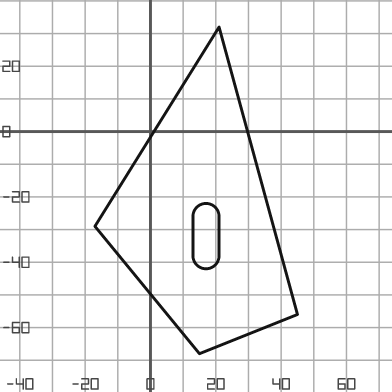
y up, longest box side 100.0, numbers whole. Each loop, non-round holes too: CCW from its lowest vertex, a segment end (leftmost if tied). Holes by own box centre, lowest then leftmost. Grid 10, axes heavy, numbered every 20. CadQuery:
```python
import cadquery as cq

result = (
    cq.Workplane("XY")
    .moveTo(15.0, -68.0)
    .lineTo(45.0, -56.0)
    .lineTo(21.0, 32.0)
    .lineTo(-17.0, -29.0)
    .close()
    .moveTo(13.0, -38.0)
    .threePointArc((17.0, -42.0), (21.0, -38.0))
    .lineTo(21.0, -26.0)
    .threePointArc((17.0, -22.0), (13.0, -26.0))
    .close()
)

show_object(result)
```